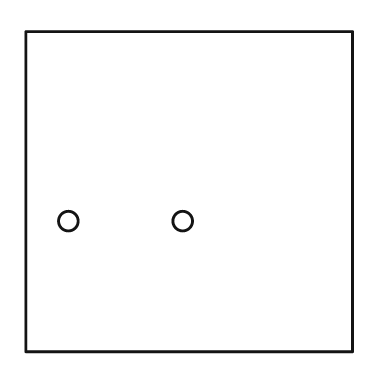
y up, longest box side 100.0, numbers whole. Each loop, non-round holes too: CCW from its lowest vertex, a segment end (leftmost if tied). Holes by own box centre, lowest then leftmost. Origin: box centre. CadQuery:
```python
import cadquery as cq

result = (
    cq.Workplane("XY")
    .moveTo(-50.0, -49.0)
    .lineTo(50.0, -49.0)
    .lineTo(50.0, 49.0)
    .lineTo(-50.0, 49.0)
    .close()
    .moveTo(-37.0, -9.0)
    .circle(3.0)
    .moveTo(-2.0, -9.0)
    .circle(3.0)
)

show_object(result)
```